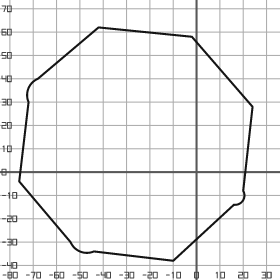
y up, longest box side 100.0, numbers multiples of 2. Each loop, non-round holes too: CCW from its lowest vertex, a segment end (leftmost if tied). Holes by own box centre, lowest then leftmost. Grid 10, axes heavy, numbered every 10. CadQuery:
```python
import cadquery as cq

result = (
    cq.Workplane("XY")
    .moveTo(-10.0, -38.0)
    .lineTo(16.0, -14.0)
    .threePointArc((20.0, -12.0), (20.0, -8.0))
    .lineTo(24.0, 28.0)
    .lineTo(-2.0, 58.0)
    .lineTo(-42.0, 62.0)
    .lineTo(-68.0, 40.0)
    .threePointArc((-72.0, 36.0), (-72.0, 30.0))
    .lineTo(-76.0, -4.0)
    .lineTo(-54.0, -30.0)
    .threePointArc((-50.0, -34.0), (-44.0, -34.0))
    .close()
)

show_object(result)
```